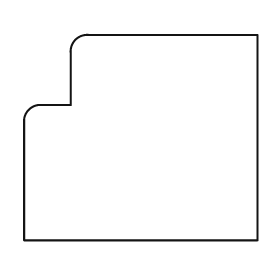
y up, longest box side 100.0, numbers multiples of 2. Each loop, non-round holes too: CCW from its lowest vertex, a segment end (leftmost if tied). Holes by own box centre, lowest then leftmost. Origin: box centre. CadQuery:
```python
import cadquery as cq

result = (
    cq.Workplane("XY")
    .moveTo(-50.0, -44.0)
    .lineTo(50.0, -44.0)
    .lineTo(50.0, 44.0)
    .lineTo(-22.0, 44.0)
    .threePointArc((-28.0, 42.0), (-30.0, 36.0))
    .lineTo(-30.0, 14.0)
    .lineTo(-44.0, 14.0)
    .threePointArc((-48.0, 12.0), (-50.0, 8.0))
    .close()
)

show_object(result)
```